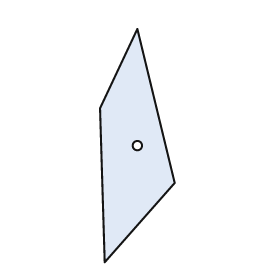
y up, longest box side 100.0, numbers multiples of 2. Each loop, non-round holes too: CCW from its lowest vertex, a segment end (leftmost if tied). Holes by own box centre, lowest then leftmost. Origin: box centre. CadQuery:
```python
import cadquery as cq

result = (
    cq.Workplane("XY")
    .moveTo(-14.0, -50.0)
    .lineTo(16.0, -16.0)
    .lineTo(0.0, 50.0)
    .lineTo(-16.0, 16.0)
    .close()
    .moveTo(0.0, 0.0)
    .circle(2.0)
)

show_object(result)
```